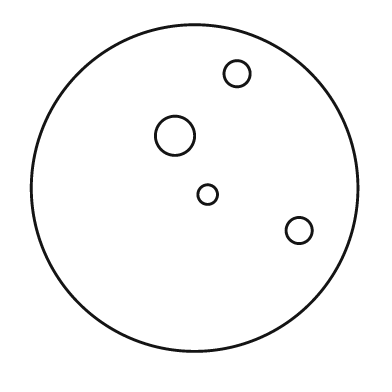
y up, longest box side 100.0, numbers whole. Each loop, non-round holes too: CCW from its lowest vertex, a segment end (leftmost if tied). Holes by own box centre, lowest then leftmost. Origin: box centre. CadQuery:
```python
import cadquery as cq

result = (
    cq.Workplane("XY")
    .moveTo(0.0, 0.0)
    .circle(50.0)
    .moveTo(32.0, -13.0)
    .circle(4.0)
    .moveTo(4.0, -2.0)
    .circle(3.0)
    .moveTo(-6.0, 16.0)
    .circle(6.0)
    .moveTo(13.0, 35.0)
    .circle(4.0)
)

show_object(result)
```